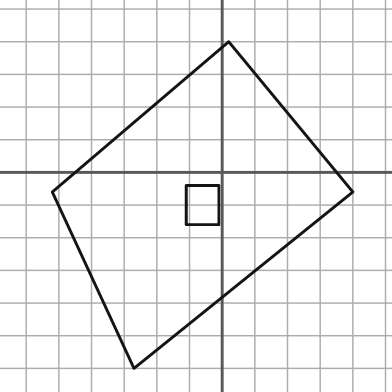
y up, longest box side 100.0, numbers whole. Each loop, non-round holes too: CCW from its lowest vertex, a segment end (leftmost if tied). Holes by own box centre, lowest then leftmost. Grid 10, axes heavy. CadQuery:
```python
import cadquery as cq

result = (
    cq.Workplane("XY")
    .moveTo(-27.0, -60.0)
    .lineTo(40.0, -6.0)
    .lineTo(2.0, 40.0)
    .lineTo(-52.0, -6.0)
    .close()
    .moveTo(-11.0, -16.0)
    .lineTo(-1.0, -16.0)
    .lineTo(-1.0, -4.0)
    .lineTo(-11.0, -4.0)
    .close()
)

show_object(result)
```